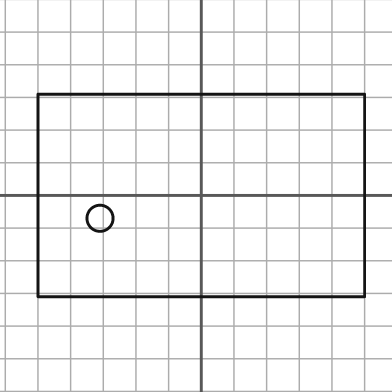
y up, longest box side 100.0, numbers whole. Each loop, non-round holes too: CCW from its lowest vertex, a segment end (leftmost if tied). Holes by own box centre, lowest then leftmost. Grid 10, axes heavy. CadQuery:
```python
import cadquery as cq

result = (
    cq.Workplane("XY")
    .moveTo(-50.0, -31.0)
    .lineTo(50.0, -31.0)
    .lineTo(50.0, 31.0)
    .lineTo(-50.0, 31.0)
    .close()
    .moveTo(-31.0, -7.0)
    .circle(4.0)
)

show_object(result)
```